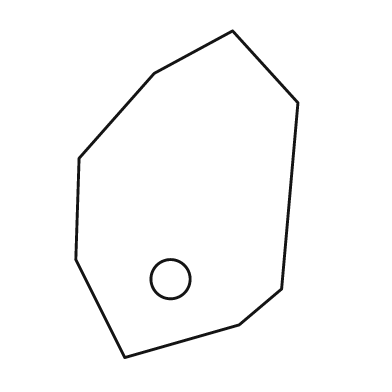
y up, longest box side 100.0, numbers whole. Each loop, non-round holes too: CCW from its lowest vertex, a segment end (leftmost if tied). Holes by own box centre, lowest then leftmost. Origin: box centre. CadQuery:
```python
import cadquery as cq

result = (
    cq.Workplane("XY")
    .moveTo(-19.0, -50.0)
    .lineTo(16.0, -40.0)
    .lineTo(29.0, -29.0)
    .lineTo(34.0, 28.0)
    .lineTo(14.0, 50.0)
    .lineTo(-10.0, 37.0)
    .lineTo(-33.0, 11.0)
    .lineTo(-34.0, -20.0)
    .close()
    .moveTo(-5.0, -26.0)
    .circle(6.0)
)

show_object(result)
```